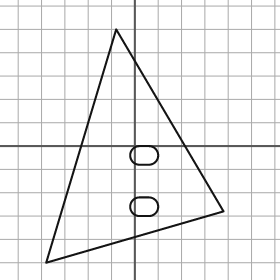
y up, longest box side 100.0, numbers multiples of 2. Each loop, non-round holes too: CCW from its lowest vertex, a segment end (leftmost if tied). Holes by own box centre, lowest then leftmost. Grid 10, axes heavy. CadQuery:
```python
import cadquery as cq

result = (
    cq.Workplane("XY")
    .moveTo(-38.0, -50.0)
    .lineTo(38.0, -28.0)
    .lineTo(-8.0, 50.0)
    .close()
    .moveTo(2.0, -30.0)
    .lineTo(6.0, -30.0)
    .threePointArc((10.0, -26.0), (6.0, -22.0))
    .lineTo(2.0, -22.0)
    .threePointArc((-2.0, -26.0), (2.0, -30.0))
    .close()
    .moveTo(2.0, -8.0)
    .lineTo(6.0, -8.0)
    .threePointArc((10.0, -4.0), (6.0, 0.0))
    .lineTo(2.0, 0.0)
    .threePointArc((-2.0, -4.0), (2.0, -8.0))
    .close()
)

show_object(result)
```